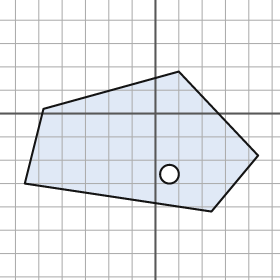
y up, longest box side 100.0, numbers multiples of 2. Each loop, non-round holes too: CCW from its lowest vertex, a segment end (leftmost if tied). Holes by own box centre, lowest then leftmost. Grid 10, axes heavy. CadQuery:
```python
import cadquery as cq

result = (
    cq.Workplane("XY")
    .moveTo(24.0, -42.0)
    .lineTo(44.0, -18.0)
    .lineTo(10.0, 18.0)
    .lineTo(-48.0, 2.0)
    .lineTo(-56.0, -30.0)
    .close()
    .moveTo(6.0, -26.0)
    .circle(4.0)
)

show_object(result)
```